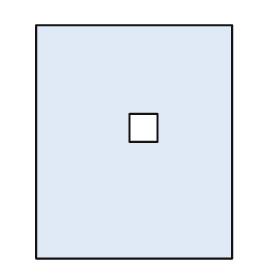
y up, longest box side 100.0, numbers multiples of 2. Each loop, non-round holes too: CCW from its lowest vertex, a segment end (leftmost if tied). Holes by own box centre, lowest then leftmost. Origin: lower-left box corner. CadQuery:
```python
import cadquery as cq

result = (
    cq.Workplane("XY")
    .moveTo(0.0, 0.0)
    .lineTo(84.0, 0.0)
    .lineTo(84.0, 100.0)
    .lineTo(0.0, 100.0)
    .close()
    .moveTo(40.0, 50.0)
    .lineTo(52.0, 50.0)
    .lineTo(52.0, 62.0)
    .lineTo(40.0, 62.0)
    .close()
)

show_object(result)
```